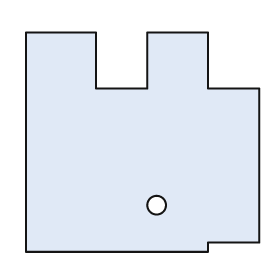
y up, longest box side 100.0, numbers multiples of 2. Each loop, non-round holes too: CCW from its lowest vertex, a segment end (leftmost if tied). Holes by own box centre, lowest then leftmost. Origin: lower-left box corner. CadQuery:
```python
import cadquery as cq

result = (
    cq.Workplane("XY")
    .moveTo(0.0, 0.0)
    .lineTo(78.0, 0.0)
    .lineTo(78.0, 4.0)
    .lineTo(100.0, 4.0)
    .lineTo(100.0, 70.0)
    .lineTo(78.0, 70.0)
    .lineTo(78.0, 94.0)
    .lineTo(52.0, 94.0)
    .lineTo(52.0, 70.0)
    .lineTo(30.0, 70.0)
    .lineTo(30.0, 94.0)
    .lineTo(0.0, 94.0)
    .close()
    .moveTo(56.0, 20.0)
    .circle(4.0)
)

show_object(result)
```